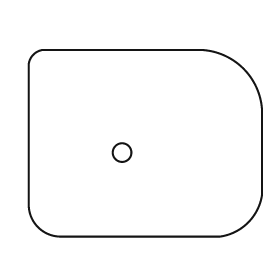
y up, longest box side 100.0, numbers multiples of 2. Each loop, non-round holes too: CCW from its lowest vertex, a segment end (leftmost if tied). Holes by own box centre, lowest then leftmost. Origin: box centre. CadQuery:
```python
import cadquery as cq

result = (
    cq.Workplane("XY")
    .moveTo(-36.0, -40.0)
    .lineTo(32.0, -40.0)
    .threePointArc((44.0, -34.0), (50.0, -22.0))
    .lineTo(50.0, 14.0)
    .threePointArc((42.0, 32.0), (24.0, 40.0))
    .lineTo(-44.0, 40.0)
    .threePointArc((-48.0, 38.0), (-50.0, 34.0))
    .lineTo(-50.0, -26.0)
    .threePointArc((-46.0, -36.0), (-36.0, -40.0))
    .close()
    .moveTo(-10.0, -4.0)
    .circle(4.0)
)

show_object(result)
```